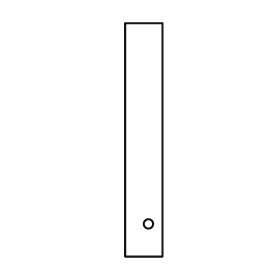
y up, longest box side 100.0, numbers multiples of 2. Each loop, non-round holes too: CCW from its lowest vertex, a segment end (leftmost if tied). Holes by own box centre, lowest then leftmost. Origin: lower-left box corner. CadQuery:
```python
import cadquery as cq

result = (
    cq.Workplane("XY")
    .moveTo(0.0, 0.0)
    .lineTo(16.0, 0.0)
    .lineTo(16.0, 100.0)
    .lineTo(0.0, 100.0)
    .close()
    .moveTo(10.0, 14.0)
    .circle(2.0)
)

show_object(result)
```